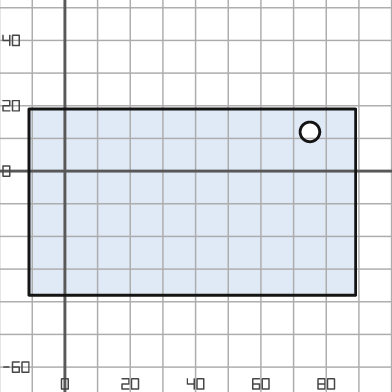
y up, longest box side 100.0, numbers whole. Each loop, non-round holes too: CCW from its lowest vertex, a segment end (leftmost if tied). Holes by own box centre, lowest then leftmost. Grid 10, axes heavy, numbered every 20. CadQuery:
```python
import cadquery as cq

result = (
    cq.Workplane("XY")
    .moveTo(-11.0, -38.0)
    .lineTo(89.0, -38.0)
    .lineTo(89.0, 19.0)
    .lineTo(-11.0, 19.0)
    .close()
    .moveTo(75.0, 12.0)
    .circle(3.0)
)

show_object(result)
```